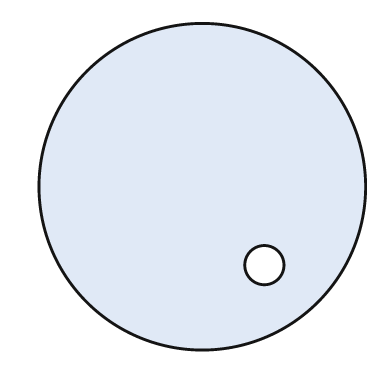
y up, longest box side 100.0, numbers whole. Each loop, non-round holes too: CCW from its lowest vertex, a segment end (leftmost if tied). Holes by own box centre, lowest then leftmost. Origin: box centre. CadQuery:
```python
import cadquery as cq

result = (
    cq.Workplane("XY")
    .moveTo(0.0, 0.0)
    .circle(50.0)
    .moveTo(19.0, -24.0)
    .circle(6.0)
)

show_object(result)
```